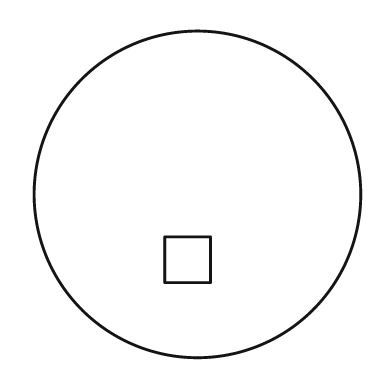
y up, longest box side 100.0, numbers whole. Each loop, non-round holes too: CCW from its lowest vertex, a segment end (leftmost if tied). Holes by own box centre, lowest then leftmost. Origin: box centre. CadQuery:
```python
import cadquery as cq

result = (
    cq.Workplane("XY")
    .moveTo(0.0, 0.0)
    .circle(50.0)
    .moveTo(-10.0, -27.0)
    .lineTo(4.0, -27.0)
    .lineTo(4.0, -13.0)
    .lineTo(-10.0, -13.0)
    .close()
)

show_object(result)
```